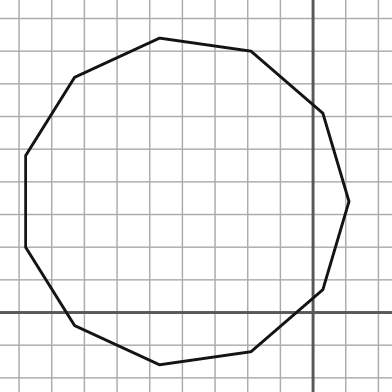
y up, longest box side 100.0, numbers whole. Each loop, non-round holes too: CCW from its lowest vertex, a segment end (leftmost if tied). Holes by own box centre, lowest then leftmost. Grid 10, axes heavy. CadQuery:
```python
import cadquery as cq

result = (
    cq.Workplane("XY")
    .moveTo(-47.0, -16.0)
    .lineTo(-19.0, -12.0)
    .lineTo(3.0, 7.0)
    .lineTo(11.0, 34.0)
    .lineTo(3.0, 61.0)
    .lineTo(-19.0, 80.0)
    .lineTo(-47.0, 84.0)
    .lineTo(-73.0, 72.0)
    .lineTo(-88.0, 48.0)
    .lineTo(-88.0, 20.0)
    .lineTo(-73.0, -4.0)
    .close()
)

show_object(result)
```